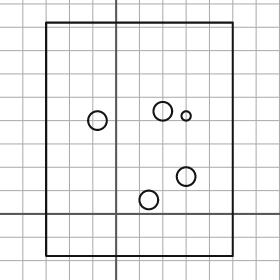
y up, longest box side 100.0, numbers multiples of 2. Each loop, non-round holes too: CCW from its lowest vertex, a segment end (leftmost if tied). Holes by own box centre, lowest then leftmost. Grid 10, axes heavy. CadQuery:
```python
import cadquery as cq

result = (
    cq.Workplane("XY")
    .moveTo(-30.0, -18.0)
    .lineTo(50.0, -18.0)
    .lineTo(50.0, 82.0)
    .lineTo(-30.0, 82.0)
    .close()
    .moveTo(14.0, 6.0)
    .circle(4.0)
    .moveTo(30.0, 16.0)
    .circle(4.0)
    .moveTo(-8.0, 40.0)
    .circle(4.0)
    .moveTo(30.0, 42.0)
    .circle(2.0)
    .moveTo(20.0, 44.0)
    .circle(4.0)
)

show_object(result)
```